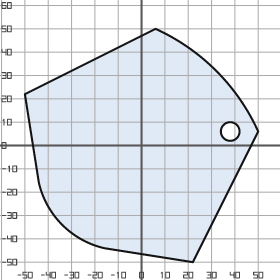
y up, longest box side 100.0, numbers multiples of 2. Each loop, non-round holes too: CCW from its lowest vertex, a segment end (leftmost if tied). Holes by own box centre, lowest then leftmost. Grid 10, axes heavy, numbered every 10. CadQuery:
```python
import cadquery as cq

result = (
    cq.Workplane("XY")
    .moveTo(22.0, -50.0)
    .lineTo(50.0, 6.0)
    .threePointArc((32.0, 32.0), (6.0, 50.0))
    .lineTo(-50.0, 22.0)
    .lineTo(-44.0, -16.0)
    .threePointArc((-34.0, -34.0), (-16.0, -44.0))
    .close()
    .moveTo(38.0, 6.0)
    .circle(4.0)
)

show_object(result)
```